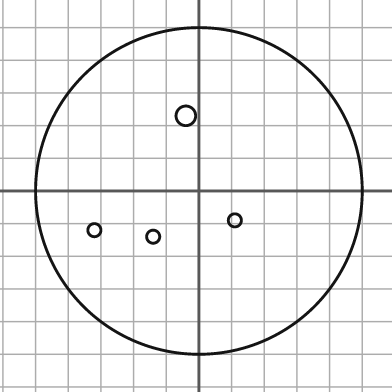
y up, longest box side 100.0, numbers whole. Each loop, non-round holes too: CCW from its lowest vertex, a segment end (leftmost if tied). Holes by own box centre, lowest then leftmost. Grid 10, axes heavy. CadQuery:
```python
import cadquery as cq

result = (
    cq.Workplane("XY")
    .moveTo(0.0, 0.0)
    .circle(50.0)
    .moveTo(-14.0, -14.0)
    .circle(2.0)
    .moveTo(-32.0, -12.0)
    .circle(2.0)
    .moveTo(11.0, -9.0)
    .circle(2.0)
    .moveTo(-4.0, 23.0)
    .circle(3.0)
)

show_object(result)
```